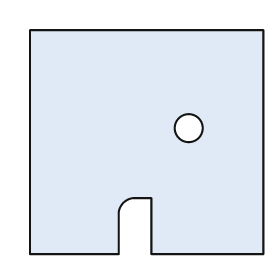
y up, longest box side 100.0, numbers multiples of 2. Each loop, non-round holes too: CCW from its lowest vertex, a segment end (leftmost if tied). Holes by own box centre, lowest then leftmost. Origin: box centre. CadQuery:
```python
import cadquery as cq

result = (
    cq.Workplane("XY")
    .moveTo(-50.0, -48.0)
    .lineTo(-12.0, -48.0)
    .lineTo(-12.0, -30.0)
    .threePointArc((-10.0, -26.0), (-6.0, -24.0))
    .lineTo(2.0, -24.0)
    .lineTo(2.0, -48.0)
    .lineTo(50.0, -48.0)
    .lineTo(50.0, 48.0)
    .lineTo(-50.0, 48.0)
    .close()
    .moveTo(18.0, 6.0)
    .circle(6.0)
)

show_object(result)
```